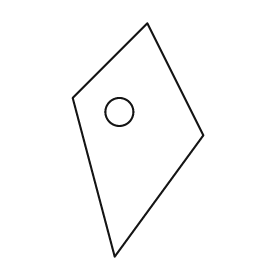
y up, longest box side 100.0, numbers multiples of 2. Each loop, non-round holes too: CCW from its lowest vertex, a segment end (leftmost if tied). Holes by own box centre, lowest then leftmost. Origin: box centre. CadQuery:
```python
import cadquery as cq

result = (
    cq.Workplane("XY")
    .moveTo(-10.0, -50.0)
    .lineTo(28.0, 2.0)
    .lineTo(4.0, 50.0)
    .lineTo(-28.0, 18.0)
    .close()
    .moveTo(-8.0, 12.0)
    .circle(6.0)
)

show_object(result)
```